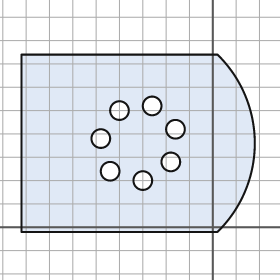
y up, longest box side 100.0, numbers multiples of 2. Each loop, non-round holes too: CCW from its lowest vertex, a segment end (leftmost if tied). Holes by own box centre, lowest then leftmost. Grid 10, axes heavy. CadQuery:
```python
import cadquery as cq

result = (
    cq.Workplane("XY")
    .moveTo(-82.0, -2.0)
    .lineTo(2.0, -2.0)
    .threePointArc((18.0, 36.0), (2.0, 74.0))
    .lineTo(-82.0, 74.0)
    .close()
    .moveTo(-30.0, 20.0)
    .circle(4.0)
    .moveTo(-44.0, 24.0)
    .circle(4.0)
    .moveTo(-18.0, 28.0)
    .circle(4.0)
    .moveTo(-48.0, 38.0)
    .circle(4.0)
    .moveTo(-16.0, 42.0)
    .circle(4.0)
    .moveTo(-40.0, 50.0)
    .circle(4.0)
    .moveTo(-26.0, 52.0)
    .circle(4.0)
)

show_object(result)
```